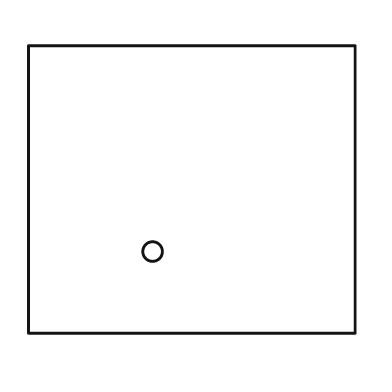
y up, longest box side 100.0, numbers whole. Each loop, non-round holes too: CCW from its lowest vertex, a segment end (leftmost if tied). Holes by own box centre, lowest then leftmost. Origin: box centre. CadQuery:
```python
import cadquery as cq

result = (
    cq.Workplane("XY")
    .moveTo(-50.0, -44.0)
    .lineTo(50.0, -44.0)
    .lineTo(50.0, 44.0)
    .lineTo(-50.0, 44.0)
    .close()
    .moveTo(-12.0, -19.0)
    .circle(3.0)
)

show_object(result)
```